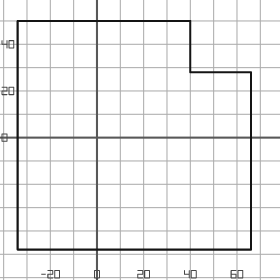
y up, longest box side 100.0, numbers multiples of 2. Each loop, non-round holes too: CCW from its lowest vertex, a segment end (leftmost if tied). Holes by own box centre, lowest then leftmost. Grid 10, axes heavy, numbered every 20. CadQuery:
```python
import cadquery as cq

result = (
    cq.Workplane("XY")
    .moveTo(-34.0, -48.0)
    .lineTo(66.0, -48.0)
    .lineTo(66.0, 28.0)
    .lineTo(40.0, 28.0)
    .lineTo(40.0, 50.0)
    .lineTo(-34.0, 50.0)
    .close()
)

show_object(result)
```